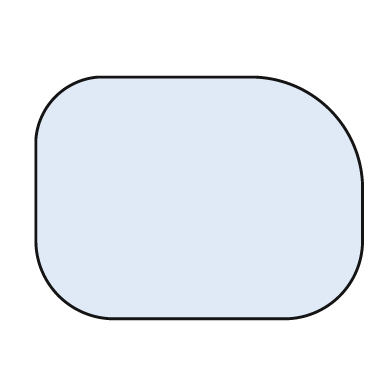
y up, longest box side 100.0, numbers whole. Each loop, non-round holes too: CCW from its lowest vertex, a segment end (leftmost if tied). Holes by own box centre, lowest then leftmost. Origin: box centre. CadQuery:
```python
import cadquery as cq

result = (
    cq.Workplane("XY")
    .moveTo(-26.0, -37.0)
    .lineTo(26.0, -37.0)
    .threePointArc((43.0, -30.0), (50.0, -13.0))
    .lineTo(50.0, 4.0)
    .threePointArc((40.0, 27.0), (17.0, 37.0))
    .lineTo(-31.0, 37.0)
    .threePointArc((-44.0, 31.0), (-50.0, 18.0))
    .lineTo(-50.0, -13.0)
    .threePointArc((-43.0, -30.0), (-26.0, -37.0))
    .close()
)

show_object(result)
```